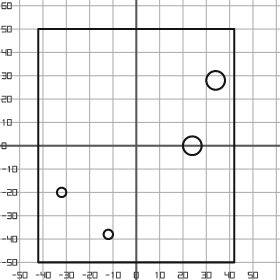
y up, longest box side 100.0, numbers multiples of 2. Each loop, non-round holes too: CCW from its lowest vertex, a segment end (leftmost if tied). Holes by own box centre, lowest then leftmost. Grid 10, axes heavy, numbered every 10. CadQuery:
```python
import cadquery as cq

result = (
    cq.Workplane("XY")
    .moveTo(-42.0, -50.0)
    .lineTo(42.0, -50.0)
    .lineTo(42.0, 50.0)
    .lineTo(-42.0, 50.0)
    .close()
    .moveTo(-12.0, -38.0)
    .circle(2.0)
    .moveTo(-32.0, -20.0)
    .circle(2.0)
    .moveTo(24.0, 0.0)
    .circle(4.0)
    .moveTo(34.0, 28.0)
    .circle(4.0)
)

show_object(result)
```